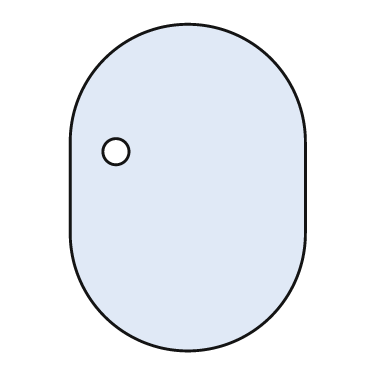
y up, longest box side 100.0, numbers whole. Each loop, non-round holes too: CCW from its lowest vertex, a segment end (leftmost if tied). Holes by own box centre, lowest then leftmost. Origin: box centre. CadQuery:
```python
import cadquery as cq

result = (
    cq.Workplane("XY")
    .moveTo(-36.0, -14.0)
    .threePointArc((0.0, -50.0), (36.0, -14.0))
    .lineTo(36.0, 14.0)
    .threePointArc((0.0, 50.0), (-36.0, 14.0))
    .close()
    .moveTo(-22.0, 11.0)
    .circle(4.0)
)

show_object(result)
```